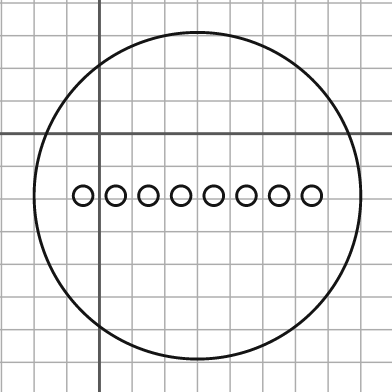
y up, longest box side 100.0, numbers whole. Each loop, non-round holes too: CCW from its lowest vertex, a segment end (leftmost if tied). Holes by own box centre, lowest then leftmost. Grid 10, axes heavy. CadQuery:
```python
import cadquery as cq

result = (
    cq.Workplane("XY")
    .moveTo(30.0, -19.0)
    .circle(50.0)
    .moveTo(-5.0, -19.0)
    .circle(3.0)
    .moveTo(5.0, -19.0)
    .circle(3.0)
    .moveTo(15.0, -19.0)
    .circle(3.0)
    .moveTo(25.0, -19.0)
    .circle(3.0)
    .moveTo(35.0, -19.0)
    .circle(3.0)
    .moveTo(45.0, -19.0)
    .circle(3.0)
    .moveTo(55.0, -19.0)
    .circle(3.0)
    .moveTo(65.0, -19.0)
    .circle(3.0)
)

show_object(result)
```